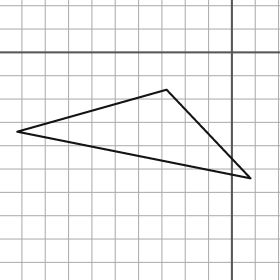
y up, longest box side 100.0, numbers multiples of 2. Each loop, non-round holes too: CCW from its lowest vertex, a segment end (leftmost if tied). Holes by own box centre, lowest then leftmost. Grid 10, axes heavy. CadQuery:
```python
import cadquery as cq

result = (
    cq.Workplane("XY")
    .moveTo(8.0, -54.0)
    .lineTo(-28.0, -16.0)
    .lineTo(-92.0, -34.0)
    .close()
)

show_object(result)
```